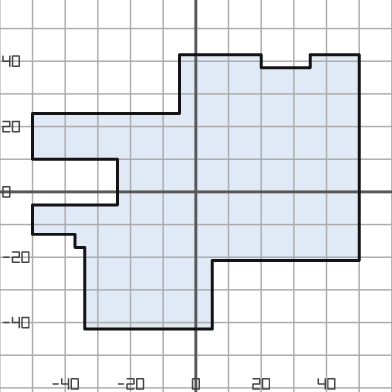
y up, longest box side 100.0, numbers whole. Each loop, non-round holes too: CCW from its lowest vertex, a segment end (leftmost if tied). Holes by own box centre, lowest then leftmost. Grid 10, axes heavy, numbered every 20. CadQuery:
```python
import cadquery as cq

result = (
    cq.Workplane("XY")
    .moveTo(-34.0, -42.0)
    .lineTo(5.0, -42.0)
    .lineTo(5.0, -21.0)
    .lineTo(50.0, -21.0)
    .lineTo(50.0, 42.0)
    .lineTo(35.0, 42.0)
    .lineTo(35.0, 38.0)
    .lineTo(20.0, 38.0)
    .lineTo(20.0, 42.0)
    .lineTo(-5.0, 42.0)
    .lineTo(-5.0, 24.0)
    .lineTo(-50.0, 24.0)
    .lineTo(-50.0, 10.0)
    .lineTo(-24.0, 10.0)
    .lineTo(-24.0, -4.0)
    .lineTo(-50.0, -4.0)
    .lineTo(-50.0, -13.0)
    .lineTo(-37.0, -13.0)
    .lineTo(-37.0, -17.0)
    .lineTo(-34.0, -17.0)
    .close()
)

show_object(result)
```